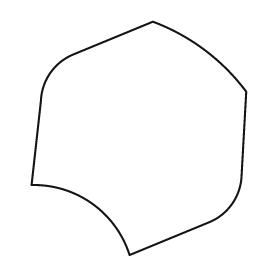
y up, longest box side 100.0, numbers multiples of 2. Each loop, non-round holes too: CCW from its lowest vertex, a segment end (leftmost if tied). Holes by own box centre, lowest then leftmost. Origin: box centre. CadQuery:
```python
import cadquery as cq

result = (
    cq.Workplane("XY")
    .moveTo(-4.0, -50.0)
    .lineTo(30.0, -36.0)
    .threePointArc((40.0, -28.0), (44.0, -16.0))
    .lineTo(46.0, 20.0)
    .threePointArc((28.0, 38.0), (6.0, 50.0))
    .lineTo(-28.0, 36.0)
    .threePointArc((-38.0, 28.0), (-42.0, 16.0))
    .lineTo(-46.0, -20.0)
    .threePointArc((-20.0, -28.0), (-4.0, -50.0))
    .close()
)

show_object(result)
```